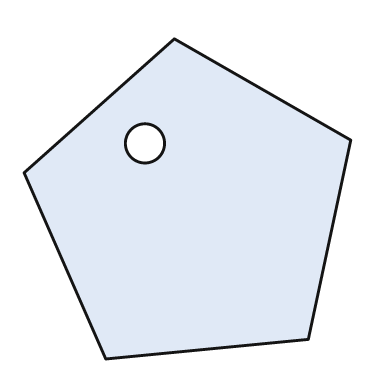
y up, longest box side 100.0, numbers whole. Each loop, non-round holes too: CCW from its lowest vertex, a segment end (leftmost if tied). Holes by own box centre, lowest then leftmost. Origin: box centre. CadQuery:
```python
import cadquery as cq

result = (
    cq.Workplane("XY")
    .moveTo(-25.0, -49.0)
    .lineTo(37.0, -43.0)
    .lineTo(50.0, 18.0)
    .lineTo(-4.0, 49.0)
    .lineTo(-50.0, 8.0)
    .close()
    .moveTo(-13.0, 17.0)
    .circle(6.0)
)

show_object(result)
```